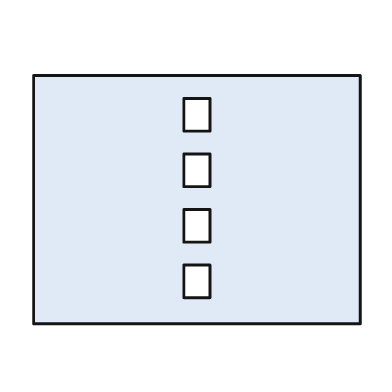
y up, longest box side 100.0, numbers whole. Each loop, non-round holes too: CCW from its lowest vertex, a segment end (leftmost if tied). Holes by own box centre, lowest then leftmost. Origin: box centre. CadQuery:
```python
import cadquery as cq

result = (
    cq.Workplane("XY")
    .moveTo(-50.0, -38.0)
    .lineTo(50.0, -38.0)
    .lineTo(50.0, 38.0)
    .lineTo(-50.0, 38.0)
    .close()
    .moveTo(-4.0, -30.0)
    .lineTo(4.0, -30.0)
    .lineTo(4.0, -20.0)
    .lineTo(-4.0, -20.0)
    .close()
    .moveTo(-4.0, -13.0)
    .lineTo(4.0, -13.0)
    .lineTo(4.0, -3.0)
    .lineTo(-4.0, -3.0)
    .close()
    .moveTo(-4.0, 4.0)
    .lineTo(4.0, 4.0)
    .lineTo(4.0, 14.0)
    .lineTo(-4.0, 14.0)
    .close()
    .moveTo(-4.0, 21.0)
    .lineTo(4.0, 21.0)
    .lineTo(4.0, 31.0)
    .lineTo(-4.0, 31.0)
    .close()
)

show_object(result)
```